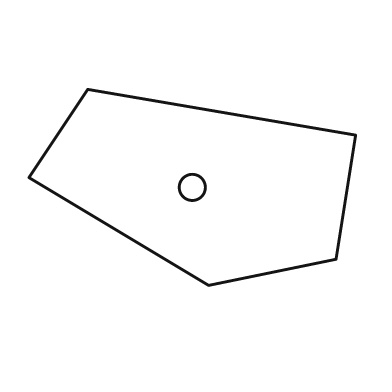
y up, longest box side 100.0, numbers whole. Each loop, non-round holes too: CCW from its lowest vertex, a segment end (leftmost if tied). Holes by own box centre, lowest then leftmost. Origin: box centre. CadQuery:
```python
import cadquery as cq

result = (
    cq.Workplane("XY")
    .moveTo(5.0, -30.0)
    .lineTo(44.0, -22.0)
    .lineTo(50.0, 16.0)
    .lineTo(-32.0, 30.0)
    .lineTo(-50.0, 3.0)
    .close()
    .moveTo(0.0, 0.0)
    .circle(4.0)
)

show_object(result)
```